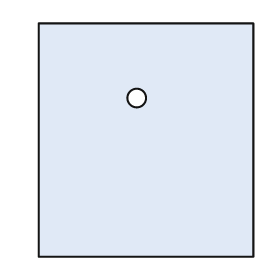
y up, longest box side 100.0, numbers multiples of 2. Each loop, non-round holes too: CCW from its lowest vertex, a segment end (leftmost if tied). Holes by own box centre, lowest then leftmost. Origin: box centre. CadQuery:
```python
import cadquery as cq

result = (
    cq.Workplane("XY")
    .moveTo(-46.0, -50.0)
    .lineTo(46.0, -50.0)
    .lineTo(46.0, 50.0)
    .lineTo(-46.0, 50.0)
    .close()
    .moveTo(-4.0, 18.0)
    .circle(4.0)
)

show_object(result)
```